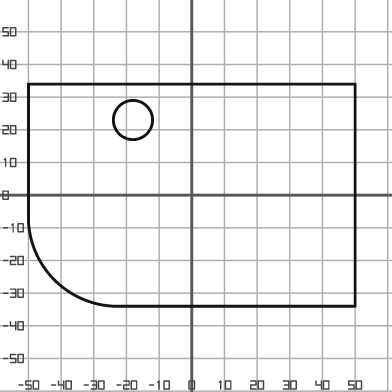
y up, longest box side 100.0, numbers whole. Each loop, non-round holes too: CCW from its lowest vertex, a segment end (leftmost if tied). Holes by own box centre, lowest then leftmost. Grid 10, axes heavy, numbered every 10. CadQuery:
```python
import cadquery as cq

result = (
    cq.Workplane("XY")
    .moveTo(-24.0, -34.0)
    .lineTo(50.0, -34.0)
    .lineTo(50.0, 34.0)
    .lineTo(-50.0, 34.0)
    .lineTo(-50.0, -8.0)
    .threePointArc((-42.0, -26.0), (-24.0, -34.0))
    .close()
    .moveTo(-18.0, 23.0)
    .circle(6.0)
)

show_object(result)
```